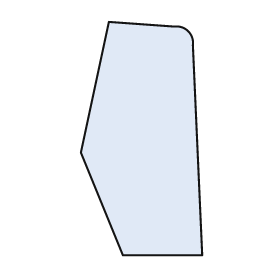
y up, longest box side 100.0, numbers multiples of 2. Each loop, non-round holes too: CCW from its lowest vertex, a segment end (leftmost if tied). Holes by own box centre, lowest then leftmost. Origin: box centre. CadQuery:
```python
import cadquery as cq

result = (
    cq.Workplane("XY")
    .moveTo(-8.0, -50.0)
    .lineTo(26.0, -50.0)
    .lineTo(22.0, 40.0)
    .threePointArc((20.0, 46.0), (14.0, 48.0))
    .lineTo(-14.0, 50.0)
    .lineTo(-26.0, -6.0)
    .close()
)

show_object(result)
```